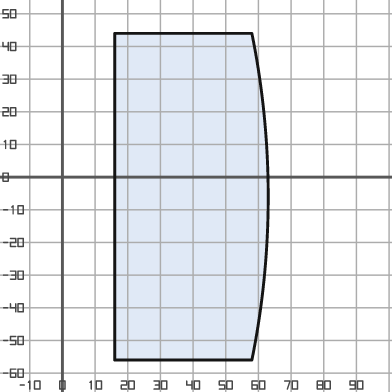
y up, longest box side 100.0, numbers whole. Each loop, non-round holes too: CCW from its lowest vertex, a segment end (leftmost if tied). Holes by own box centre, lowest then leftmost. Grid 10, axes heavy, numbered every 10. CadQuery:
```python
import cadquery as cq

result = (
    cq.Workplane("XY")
    .moveTo(16.0, -56.0)
    .lineTo(58.0, -56.0)
    .threePointArc((63.0, -6.0), (58.0, 44.0))
    .lineTo(16.0, 44.0)
    .close()
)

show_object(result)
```